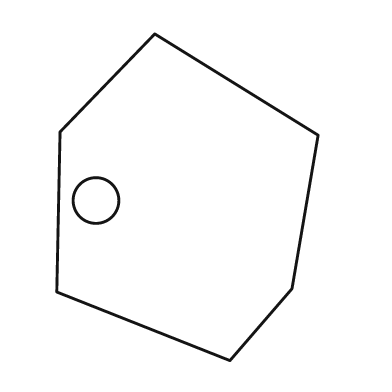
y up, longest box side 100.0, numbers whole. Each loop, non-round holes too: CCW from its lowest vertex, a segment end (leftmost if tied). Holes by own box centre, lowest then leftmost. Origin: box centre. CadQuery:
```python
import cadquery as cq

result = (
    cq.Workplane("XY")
    .moveTo(13.0, -50.0)
    .lineTo(32.0, -28.0)
    .lineTo(40.0, 19.0)
    .lineTo(-10.0, 50.0)
    .lineTo(-39.0, 20.0)
    .lineTo(-40.0, -29.0)
    .close()
    .moveTo(-28.0, -1.0)
    .circle(7.0)
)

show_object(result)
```